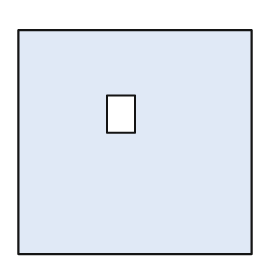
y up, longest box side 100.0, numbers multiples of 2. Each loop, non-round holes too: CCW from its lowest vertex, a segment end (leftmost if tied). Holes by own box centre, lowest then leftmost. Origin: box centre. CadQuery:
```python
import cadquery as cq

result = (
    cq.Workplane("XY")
    .moveTo(-50.0, -48.0)
    .lineTo(50.0, -48.0)
    .lineTo(50.0, 48.0)
    .lineTo(-50.0, 48.0)
    .close()
    .moveTo(-12.0, 4.0)
    .lineTo(0.0, 4.0)
    .lineTo(0.0, 20.0)
    .lineTo(-12.0, 20.0)
    .close()
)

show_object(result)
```